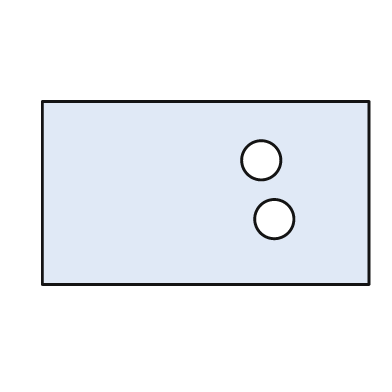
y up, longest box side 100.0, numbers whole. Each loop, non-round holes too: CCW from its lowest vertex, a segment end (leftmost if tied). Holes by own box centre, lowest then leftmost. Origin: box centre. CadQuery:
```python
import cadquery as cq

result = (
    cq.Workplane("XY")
    .moveTo(-50.0, -28.0)
    .lineTo(50.0, -28.0)
    .lineTo(50.0, 28.0)
    .lineTo(-50.0, 28.0)
    .close()
    .moveTo(21.0, -8.0)
    .circle(6.0)
    .moveTo(17.0, 10.0)
    .circle(6.0)
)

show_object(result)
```